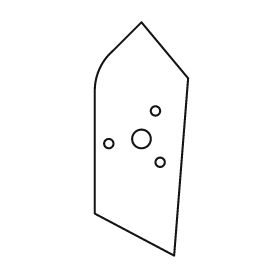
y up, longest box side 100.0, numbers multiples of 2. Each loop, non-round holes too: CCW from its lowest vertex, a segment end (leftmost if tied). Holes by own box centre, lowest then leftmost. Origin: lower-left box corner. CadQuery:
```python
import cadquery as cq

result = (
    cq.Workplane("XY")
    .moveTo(34.0, 0.0)
    .lineTo(40.0, 76.0)
    .lineTo(20.0, 100.0)
    .lineTo(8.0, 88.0)
    .threePointArc((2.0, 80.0), (0.0, 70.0))
    .lineTo(0.0, 18.0)
    .close()
    .moveTo(28.0, 40.0)
    .circle(2.0)
    .moveTo(6.0, 48.0)
    .circle(2.0)
    .moveTo(20.0, 50.0)
    .circle(4.0)
    .moveTo(26.0, 62.0)
    .circle(2.0)
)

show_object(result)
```